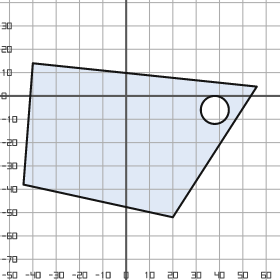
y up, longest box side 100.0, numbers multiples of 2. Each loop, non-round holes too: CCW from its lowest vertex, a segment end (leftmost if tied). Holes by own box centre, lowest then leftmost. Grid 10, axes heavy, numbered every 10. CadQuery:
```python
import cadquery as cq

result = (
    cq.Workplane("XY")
    .moveTo(20.0, -52.0)
    .lineTo(56.0, 4.0)
    .lineTo(-40.0, 14.0)
    .lineTo(-44.0, -38.0)
    .close()
    .moveTo(38.0, -6.0)
    .circle(6.0)
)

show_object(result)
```